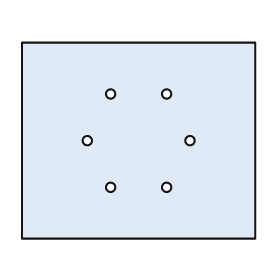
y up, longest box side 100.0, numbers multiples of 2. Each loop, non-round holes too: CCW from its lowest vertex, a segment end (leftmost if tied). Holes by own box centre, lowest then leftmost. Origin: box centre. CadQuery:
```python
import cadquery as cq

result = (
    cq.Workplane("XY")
    .moveTo(-50.0, -42.0)
    .lineTo(50.0, -42.0)
    .lineTo(50.0, 42.0)
    .lineTo(-50.0, 42.0)
    .close()
    .moveTo(-12.0, -20.0)
    .circle(2.0)
    .moveTo(12.0, -20.0)
    .circle(2.0)
    .moveTo(-22.0, 0.0)
    .circle(2.0)
    .moveTo(22.0, 0.0)
    .circle(2.0)
    .moveTo(-12.0, 20.0)
    .circle(2.0)
    .moveTo(12.0, 20.0)
    .circle(2.0)
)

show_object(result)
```